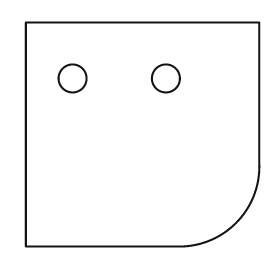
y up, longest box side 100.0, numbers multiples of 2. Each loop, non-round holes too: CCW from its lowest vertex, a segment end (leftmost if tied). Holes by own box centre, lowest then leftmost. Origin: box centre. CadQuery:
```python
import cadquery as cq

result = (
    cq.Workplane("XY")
    .moveTo(-50.0, -48.0)
    .lineTo(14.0, -48.0)
    .threePointArc((40.0, -38.0), (50.0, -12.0))
    .lineTo(50.0, 48.0)
    .lineTo(-50.0, 48.0)
    .close()
    .moveTo(-30.0, 24.0)
    .circle(6.0)
    .moveTo(10.0, 24.0)
    .circle(6.0)
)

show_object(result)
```